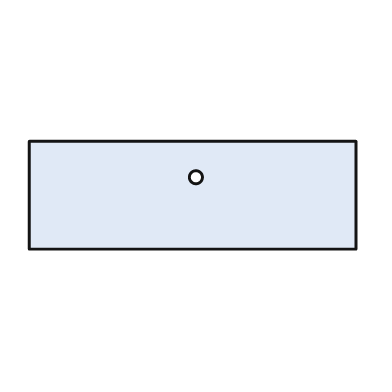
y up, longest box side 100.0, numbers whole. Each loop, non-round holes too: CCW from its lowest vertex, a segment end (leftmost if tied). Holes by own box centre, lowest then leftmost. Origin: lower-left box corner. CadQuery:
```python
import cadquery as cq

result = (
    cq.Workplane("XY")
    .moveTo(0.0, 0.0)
    .lineTo(100.0, 0.0)
    .lineTo(100.0, 33.0)
    .lineTo(0.0, 33.0)
    .close()
    .moveTo(51.0, 22.0)
    .circle(2.0)
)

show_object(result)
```